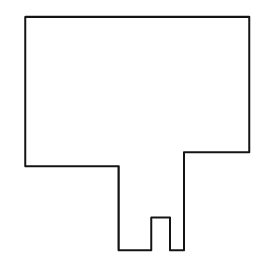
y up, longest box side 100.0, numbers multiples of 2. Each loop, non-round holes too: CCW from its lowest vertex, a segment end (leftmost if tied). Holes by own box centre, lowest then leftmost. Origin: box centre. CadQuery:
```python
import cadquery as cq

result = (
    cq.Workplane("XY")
    .moveTo(-8.0, -50.0)
    .lineTo(6.0, -50.0)
    .lineTo(6.0, -36.0)
    .lineTo(14.0, -36.0)
    .lineTo(14.0, -50.0)
    .lineTo(20.0, -50.0)
    .lineTo(20.0, -8.0)
    .lineTo(48.0, -8.0)
    .lineTo(48.0, 50.0)
    .lineTo(-48.0, 50.0)
    .lineTo(-48.0, -14.0)
    .lineTo(-8.0, -14.0)
    .close()
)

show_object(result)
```